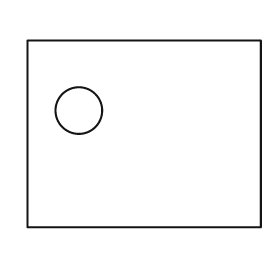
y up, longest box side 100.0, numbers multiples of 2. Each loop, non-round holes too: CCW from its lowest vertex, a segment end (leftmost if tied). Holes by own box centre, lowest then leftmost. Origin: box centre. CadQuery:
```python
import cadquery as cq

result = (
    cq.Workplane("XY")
    .moveTo(-50.0, -40.0)
    .lineTo(50.0, -40.0)
    .lineTo(50.0, 40.0)
    .lineTo(-50.0, 40.0)
    .close()
    .moveTo(-28.0, 10.0)
    .circle(10.0)
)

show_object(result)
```